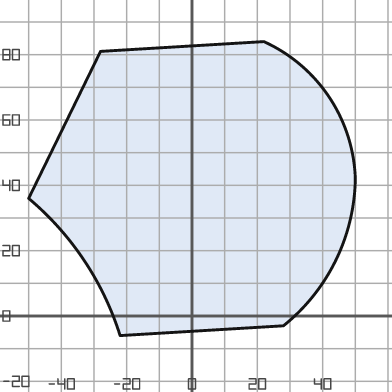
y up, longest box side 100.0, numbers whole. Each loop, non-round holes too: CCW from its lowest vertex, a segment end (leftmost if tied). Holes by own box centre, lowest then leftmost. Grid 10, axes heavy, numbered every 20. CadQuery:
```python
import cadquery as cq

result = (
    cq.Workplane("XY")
    .moveTo(-22.0, -6.0)
    .lineTo(28.0, -3.0)
    .threePointArc((44.0, 17.0), (50.0, 42.0))
    .threePointArc((42.0, 67.0), (22.0, 84.0))
    .lineTo(-28.0, 81.0)
    .lineTo(-50.0, 36.0)
    .threePointArc((-33.0, 17.0), (-22.0, -6.0))
    .close()
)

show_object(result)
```